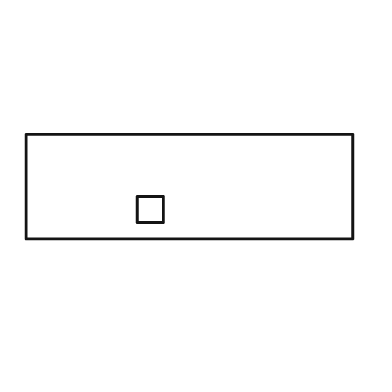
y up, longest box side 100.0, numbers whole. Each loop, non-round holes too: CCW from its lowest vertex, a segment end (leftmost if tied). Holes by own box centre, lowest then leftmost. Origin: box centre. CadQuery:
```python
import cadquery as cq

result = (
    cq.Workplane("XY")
    .moveTo(-50.0, -16.0)
    .lineTo(50.0, -16.0)
    .lineTo(50.0, 16.0)
    .lineTo(-50.0, 16.0)
    .close()
    .moveTo(-16.0, -11.0)
    .lineTo(-8.0, -11.0)
    .lineTo(-8.0, -3.0)
    .lineTo(-16.0, -3.0)
    .close()
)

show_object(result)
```